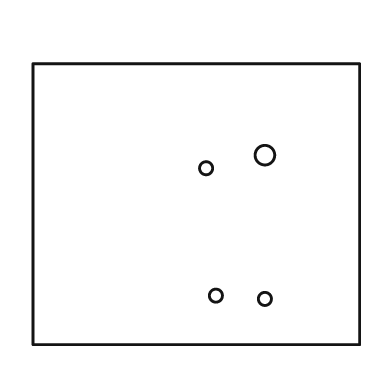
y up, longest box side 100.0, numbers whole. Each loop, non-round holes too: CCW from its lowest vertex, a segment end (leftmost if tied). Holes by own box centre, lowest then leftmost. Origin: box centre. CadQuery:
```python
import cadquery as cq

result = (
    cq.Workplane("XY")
    .moveTo(-50.0, -43.0)
    .lineTo(50.0, -43.0)
    .lineTo(50.0, 43.0)
    .lineTo(-50.0, 43.0)
    .close()
    .moveTo(21.0, -29.0)
    .circle(2.0)
    .moveTo(6.0, -28.0)
    .circle(2.0)
    .moveTo(3.0, 11.0)
    .circle(2.0)
    .moveTo(21.0, 15.0)
    .circle(3.0)
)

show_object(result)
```